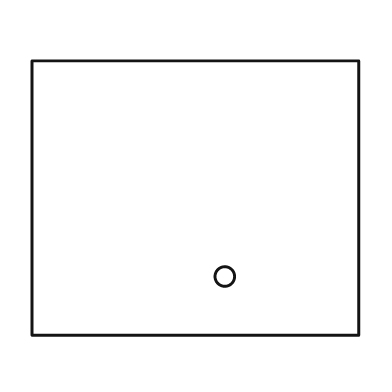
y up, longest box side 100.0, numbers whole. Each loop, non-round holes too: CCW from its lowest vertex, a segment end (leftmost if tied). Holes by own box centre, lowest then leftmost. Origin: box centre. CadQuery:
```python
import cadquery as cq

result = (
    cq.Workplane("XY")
    .moveTo(-50.0, -42.0)
    .lineTo(50.0, -42.0)
    .lineTo(50.0, 42.0)
    .lineTo(-50.0, 42.0)
    .close()
    .moveTo(9.0, -24.0)
    .circle(3.0)
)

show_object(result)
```